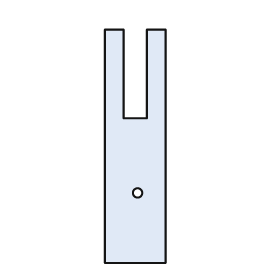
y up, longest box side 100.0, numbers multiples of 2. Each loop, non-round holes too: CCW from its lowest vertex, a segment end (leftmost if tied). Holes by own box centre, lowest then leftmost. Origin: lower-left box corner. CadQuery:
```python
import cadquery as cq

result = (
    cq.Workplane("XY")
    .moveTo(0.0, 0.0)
    .lineTo(26.0, 0.0)
    .lineTo(26.0, 100.0)
    .lineTo(18.0, 100.0)
    .lineTo(18.0, 62.0)
    .lineTo(8.0, 62.0)
    .lineTo(8.0, 100.0)
    .lineTo(0.0, 100.0)
    .close()
    .moveTo(14.0, 30.0)
    .circle(2.0)
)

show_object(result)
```